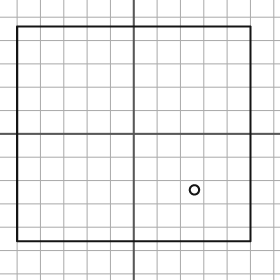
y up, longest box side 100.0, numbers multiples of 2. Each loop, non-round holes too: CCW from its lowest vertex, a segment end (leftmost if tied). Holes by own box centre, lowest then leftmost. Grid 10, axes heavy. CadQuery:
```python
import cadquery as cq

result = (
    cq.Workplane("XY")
    .moveTo(-50.0, -46.0)
    .lineTo(50.0, -46.0)
    .lineTo(50.0, 46.0)
    .lineTo(-50.0, 46.0)
    .close()
    .moveTo(26.0, -24.0)
    .circle(2.0)
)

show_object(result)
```